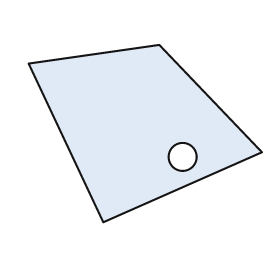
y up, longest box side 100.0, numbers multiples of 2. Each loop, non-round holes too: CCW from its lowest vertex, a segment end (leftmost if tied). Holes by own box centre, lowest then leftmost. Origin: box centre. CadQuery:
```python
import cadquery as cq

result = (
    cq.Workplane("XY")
    .moveTo(-18.0, -38.0)
    .lineTo(50.0, -8.0)
    .lineTo(6.0, 38.0)
    .lineTo(-50.0, 30.0)
    .close()
    .moveTo(16.0, -10.0)
    .circle(6.0)
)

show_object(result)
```